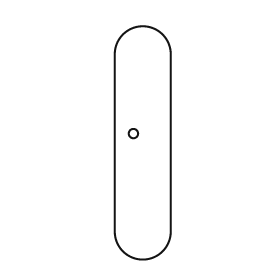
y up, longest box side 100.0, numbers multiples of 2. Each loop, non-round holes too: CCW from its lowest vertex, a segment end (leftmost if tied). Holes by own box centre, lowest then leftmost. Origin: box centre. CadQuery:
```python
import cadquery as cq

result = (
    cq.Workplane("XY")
    .moveTo(-12.0, -38.0)
    .threePointArc((0.0, -50.0), (12.0, -38.0))
    .lineTo(12.0, 38.0)
    .threePointArc((0.0, 50.0), (-12.0, 38.0))
    .close()
    .moveTo(-4.0, 4.0)
    .circle(2.0)
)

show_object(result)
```